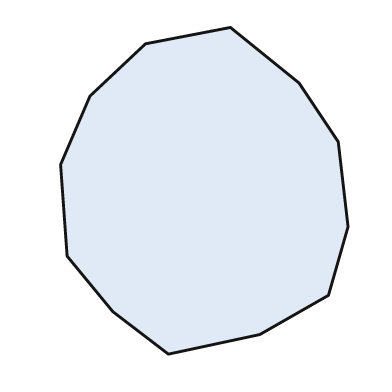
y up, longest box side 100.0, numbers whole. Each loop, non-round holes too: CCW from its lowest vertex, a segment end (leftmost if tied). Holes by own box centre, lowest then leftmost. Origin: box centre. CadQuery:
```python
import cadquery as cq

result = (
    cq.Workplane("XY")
    .moveTo(-11.0, -50.0)
    .lineTo(17.0, -44.0)
    .lineTo(38.0, -32.0)
    .lineTo(44.0, -11.0)
    .lineTo(41.0, 15.0)
    .lineTo(29.0, 33.0)
    .lineTo(8.0, 50.0)
    .lineTo(-18.0, 45.0)
    .lineTo(-35.0, 29.0)
    .lineTo(-44.0, 8.0)
    .lineTo(-42.0, -20.0)
    .lineTo(-28.0, -37.0)
    .close()
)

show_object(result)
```